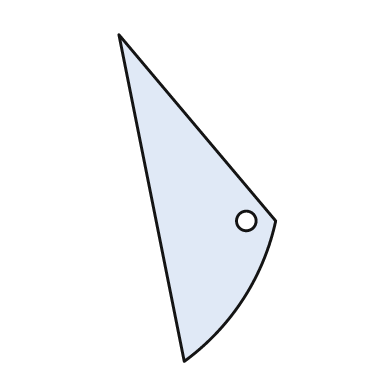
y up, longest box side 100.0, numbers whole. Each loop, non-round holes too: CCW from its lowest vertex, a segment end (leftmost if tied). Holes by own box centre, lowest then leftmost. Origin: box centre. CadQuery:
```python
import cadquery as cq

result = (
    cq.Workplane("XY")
    .moveTo(-4.0, -50.0)
    .threePointArc((14.0, -31.0), (24.0, -7.0))
    .lineTo(-24.0, 50.0)
    .close()
    .moveTo(15.0, -7.0)
    .circle(3.0)
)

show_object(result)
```